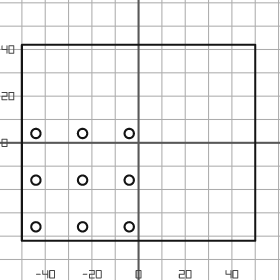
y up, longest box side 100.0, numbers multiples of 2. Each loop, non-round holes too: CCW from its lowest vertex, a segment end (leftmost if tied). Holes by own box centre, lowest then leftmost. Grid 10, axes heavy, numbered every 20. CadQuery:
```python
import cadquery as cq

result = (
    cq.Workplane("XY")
    .moveTo(-50.0, -42.0)
    .lineTo(50.0, -42.0)
    .lineTo(50.0, 42.0)
    .lineTo(-50.0, 42.0)
    .close()
    .moveTo(-44.0, -36.0)
    .circle(2.0)
    .moveTo(-24.0, -36.0)
    .circle(2.0)
    .moveTo(-4.0, -36.0)
    .circle(2.0)
    .moveTo(-44.0, -16.0)
    .circle(2.0)
    .moveTo(-24.0, -16.0)
    .circle(2.0)
    .moveTo(-4.0, -16.0)
    .circle(2.0)
    .moveTo(-44.0, 4.0)
    .circle(2.0)
    .moveTo(-24.0, 4.0)
    .circle(2.0)
    .moveTo(-4.0, 4.0)
    .circle(2.0)
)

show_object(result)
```